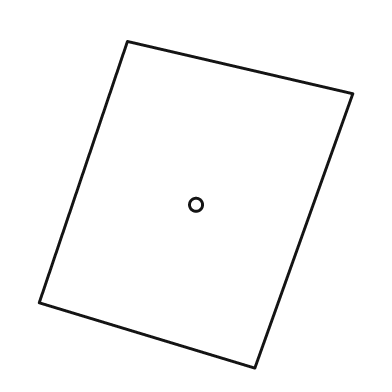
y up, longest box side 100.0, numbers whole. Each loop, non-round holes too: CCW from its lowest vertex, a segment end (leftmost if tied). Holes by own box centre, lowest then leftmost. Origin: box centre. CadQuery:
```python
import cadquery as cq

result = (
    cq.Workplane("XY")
    .moveTo(18.0, -50.0)
    .lineTo(48.0, 34.0)
    .lineTo(-21.0, 50.0)
    .lineTo(-48.0, -30.0)
    .close()
    .moveTo(0.0, 0.0)
    .circle(2.0)
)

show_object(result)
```